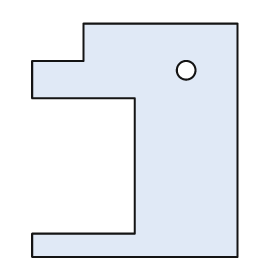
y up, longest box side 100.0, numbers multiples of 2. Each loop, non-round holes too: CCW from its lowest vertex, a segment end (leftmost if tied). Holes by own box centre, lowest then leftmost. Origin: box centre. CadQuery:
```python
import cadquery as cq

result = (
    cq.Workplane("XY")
    .moveTo(-44.0, -50.0)
    .lineTo(44.0, -50.0)
    .lineTo(44.0, 50.0)
    .lineTo(-22.0, 50.0)
    .lineTo(-22.0, 34.0)
    .lineTo(-44.0, 34.0)
    .lineTo(-44.0, 18.0)
    .lineTo(0.0, 18.0)
    .lineTo(0.0, -40.0)
    .lineTo(-44.0, -40.0)
    .close()
    .moveTo(22.0, 30.0)
    .circle(4.0)
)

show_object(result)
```